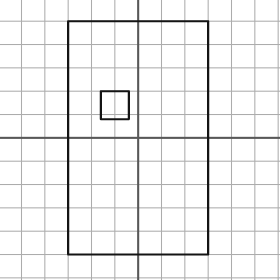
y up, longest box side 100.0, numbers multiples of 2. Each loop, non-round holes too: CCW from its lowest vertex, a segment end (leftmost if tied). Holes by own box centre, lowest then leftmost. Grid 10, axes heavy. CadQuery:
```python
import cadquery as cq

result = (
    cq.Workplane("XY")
    .moveTo(-30.0, -50.0)
    .lineTo(30.0, -50.0)
    .lineTo(30.0, 50.0)
    .lineTo(-30.0, 50.0)
    .close()
    .moveTo(-16.0, 8.0)
    .lineTo(-4.0, 8.0)
    .lineTo(-4.0, 20.0)
    .lineTo(-16.0, 20.0)
    .close()
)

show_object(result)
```